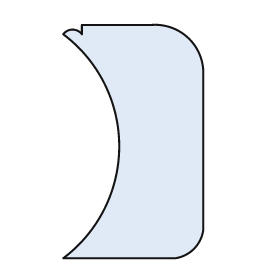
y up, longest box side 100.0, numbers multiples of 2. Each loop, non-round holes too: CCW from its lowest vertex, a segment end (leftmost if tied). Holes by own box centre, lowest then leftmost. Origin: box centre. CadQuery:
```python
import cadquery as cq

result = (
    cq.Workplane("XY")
    .moveTo(-30.0, -50.0)
    .lineTo(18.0, -50.0)
    .threePointArc((26.0, -46.0), (30.0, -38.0))
    .lineTo(30.0, 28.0)
    .threePointArc((24.0, 44.0), (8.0, 50.0))
    .lineTo(-22.0, 50.0)
    .lineTo(-22.0, 46.0)
    .threePointArc((-26.0, 48.0), (-30.0, 46.0))
    .threePointArc((-6.0, -2.0), (-30.0, -50.0))
    .close()
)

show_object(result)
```